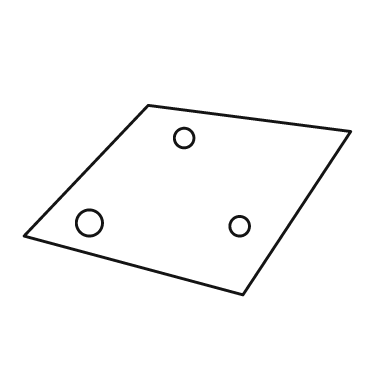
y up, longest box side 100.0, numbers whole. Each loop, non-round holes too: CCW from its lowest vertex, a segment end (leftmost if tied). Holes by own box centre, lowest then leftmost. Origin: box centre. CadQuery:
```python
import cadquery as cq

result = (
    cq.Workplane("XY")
    .moveTo(17.0, -29.0)
    .lineTo(50.0, 21.0)
    .lineTo(-12.0, 29.0)
    .lineTo(-50.0, -11.0)
    .close()
    .moveTo(16.0, -8.0)
    .circle(3.0)
    .moveTo(-30.0, -7.0)
    .circle(4.0)
    .moveTo(-1.0, 19.0)
    .circle(3.0)
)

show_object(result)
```